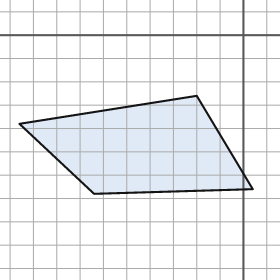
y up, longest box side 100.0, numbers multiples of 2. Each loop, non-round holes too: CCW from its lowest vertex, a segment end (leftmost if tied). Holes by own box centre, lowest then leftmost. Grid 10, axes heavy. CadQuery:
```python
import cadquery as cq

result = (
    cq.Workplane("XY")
    .moveTo(-64.0, -68.0)
    .lineTo(4.0, -66.0)
    .lineTo(-20.0, -26.0)
    .lineTo(-96.0, -38.0)
    .close()
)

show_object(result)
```